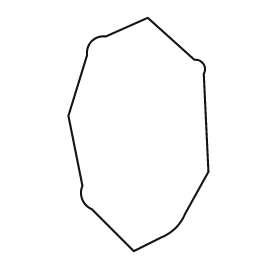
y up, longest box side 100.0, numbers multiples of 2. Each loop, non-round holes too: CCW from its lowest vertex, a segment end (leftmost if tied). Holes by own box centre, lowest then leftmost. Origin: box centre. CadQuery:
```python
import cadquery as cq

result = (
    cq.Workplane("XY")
    .moveTo(-2.0, -50.0)
    .lineTo(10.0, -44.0)
    .threePointArc((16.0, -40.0), (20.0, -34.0))
    .lineTo(30.0, -16.0)
    .lineTo(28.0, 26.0)
    .threePointArc((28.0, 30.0), (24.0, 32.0))
    .lineTo(4.0, 50.0)
    .lineTo(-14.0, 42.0)
    .threePointArc((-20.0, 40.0), (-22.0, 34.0))
    .lineTo(-30.0, 8.0)
    .lineTo(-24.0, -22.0)
    .threePointArc((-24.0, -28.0), (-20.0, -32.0))
    .close()
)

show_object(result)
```